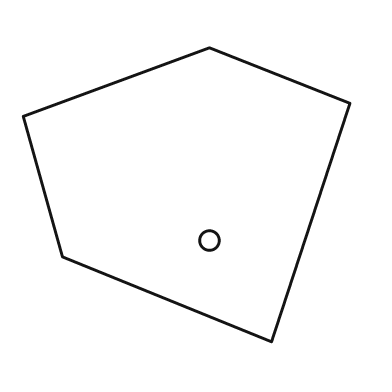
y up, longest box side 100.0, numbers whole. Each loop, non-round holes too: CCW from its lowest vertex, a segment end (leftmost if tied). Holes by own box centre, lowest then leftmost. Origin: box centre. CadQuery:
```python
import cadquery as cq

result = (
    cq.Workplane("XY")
    .moveTo(26.0, -45.0)
    .lineTo(50.0, 28.0)
    .lineTo(7.0, 45.0)
    .lineTo(-50.0, 24.0)
    .lineTo(-38.0, -19.0)
    .close()
    .moveTo(7.0, -14.0)
    .circle(3.0)
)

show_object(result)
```